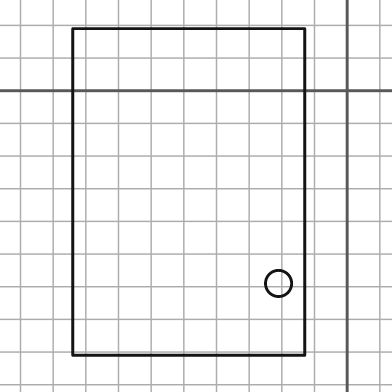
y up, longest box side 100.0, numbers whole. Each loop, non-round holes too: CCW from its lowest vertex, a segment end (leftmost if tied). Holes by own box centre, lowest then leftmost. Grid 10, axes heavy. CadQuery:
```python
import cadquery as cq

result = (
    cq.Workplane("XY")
    .moveTo(-84.0, -81.0)
    .lineTo(-13.0, -81.0)
    .lineTo(-13.0, 19.0)
    .lineTo(-84.0, 19.0)
    .close()
    .moveTo(-21.0, -59.0)
    .circle(4.0)
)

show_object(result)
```